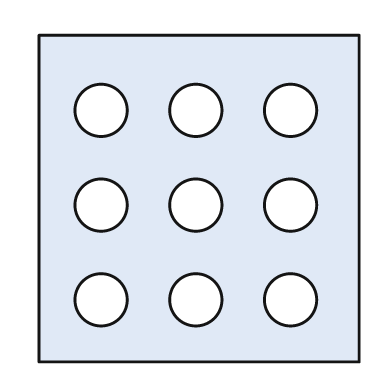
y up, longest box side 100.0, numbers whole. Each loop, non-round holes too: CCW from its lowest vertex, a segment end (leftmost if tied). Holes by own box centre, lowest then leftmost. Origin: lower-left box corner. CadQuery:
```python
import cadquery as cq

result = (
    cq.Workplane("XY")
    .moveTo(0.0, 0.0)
    .lineTo(98.0, 0.0)
    .lineTo(98.0, 100.0)
    .lineTo(0.0, 100.0)
    .close()
    .moveTo(19.0, 19.0)
    .circle(8.0)
    .moveTo(48.0, 19.0)
    .circle(8.0)
    .moveTo(77.0, 19.0)
    .circle(8.0)
    .moveTo(19.0, 48.0)
    .circle(8.0)
    .moveTo(48.0, 48.0)
    .circle(8.0)
    .moveTo(77.0, 48.0)
    .circle(8.0)
    .moveTo(19.0, 77.0)
    .circle(8.0)
    .moveTo(48.0, 77.0)
    .circle(8.0)
    .moveTo(77.0, 77.0)
    .circle(8.0)
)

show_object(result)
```